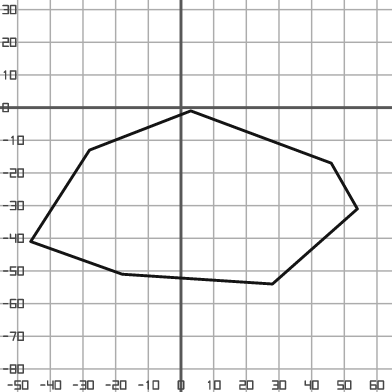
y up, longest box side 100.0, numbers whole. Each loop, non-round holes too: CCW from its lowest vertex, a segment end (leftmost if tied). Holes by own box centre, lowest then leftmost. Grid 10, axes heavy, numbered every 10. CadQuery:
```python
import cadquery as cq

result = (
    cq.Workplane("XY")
    .moveTo(28.0, -54.0)
    .lineTo(54.0, -31.0)
    .lineTo(46.0, -17.0)
    .lineTo(3.0, -1.0)
    .lineTo(-28.0, -13.0)
    .lineTo(-46.0, -41.0)
    .lineTo(-18.0, -51.0)
    .close()
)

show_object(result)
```